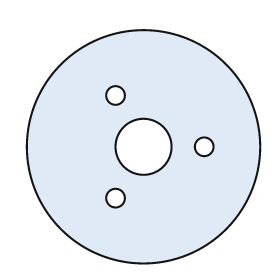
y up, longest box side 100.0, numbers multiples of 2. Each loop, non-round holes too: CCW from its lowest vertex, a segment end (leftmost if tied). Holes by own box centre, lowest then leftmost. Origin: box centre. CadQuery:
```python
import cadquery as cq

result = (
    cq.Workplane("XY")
    .moveTo(0.0, 0.0)
    .circle(50.0)
    .moveTo(-12.0, -22.0)
    .circle(4.0)
    .moveTo(0.0, 0.0)
    .circle(12.0)
    .moveTo(26.0, 0.0)
    .circle(4.0)
    .moveTo(-12.0, 22.0)
    .circle(4.0)
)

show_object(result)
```